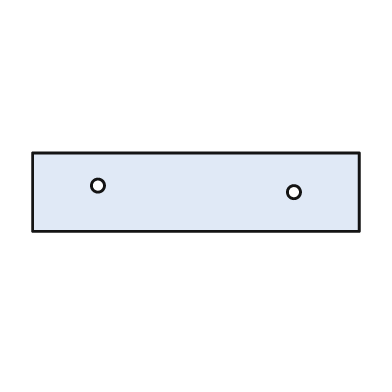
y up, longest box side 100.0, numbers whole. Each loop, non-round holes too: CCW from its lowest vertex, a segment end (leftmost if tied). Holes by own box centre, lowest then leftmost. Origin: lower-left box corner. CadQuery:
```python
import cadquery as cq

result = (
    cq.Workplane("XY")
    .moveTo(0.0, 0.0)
    .lineTo(100.0, 0.0)
    .lineTo(100.0, 24.0)
    .lineTo(0.0, 24.0)
    .close()
    .moveTo(80.0, 12.0)
    .circle(2.0)
    .moveTo(20.0, 14.0)
    .circle(2.0)
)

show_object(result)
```